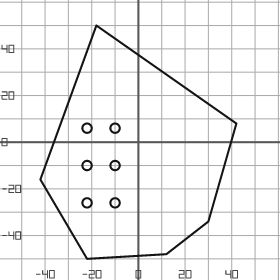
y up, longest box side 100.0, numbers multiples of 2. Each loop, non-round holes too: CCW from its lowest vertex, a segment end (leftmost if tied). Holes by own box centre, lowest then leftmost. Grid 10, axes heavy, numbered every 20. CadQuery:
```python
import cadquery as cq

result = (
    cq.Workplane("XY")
    .moveTo(-22.0, -50.0)
    .lineTo(12.0, -48.0)
    .lineTo(30.0, -34.0)
    .lineTo(42.0, 8.0)
    .lineTo(-18.0, 50.0)
    .lineTo(-42.0, -16.0)
    .close()
    .moveTo(-22.0, -26.0)
    .circle(2.0)
    .moveTo(-10.0, -26.0)
    .circle(2.0)
    .moveTo(-22.0, -10.0)
    .circle(2.0)
    .moveTo(-10.0, -10.0)
    .circle(2.0)
    .moveTo(-22.0, 6.0)
    .circle(2.0)
    .moveTo(-10.0, 6.0)
    .circle(2.0)
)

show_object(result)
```